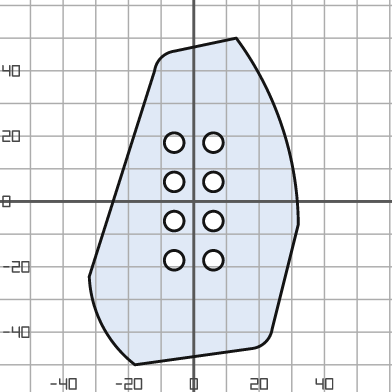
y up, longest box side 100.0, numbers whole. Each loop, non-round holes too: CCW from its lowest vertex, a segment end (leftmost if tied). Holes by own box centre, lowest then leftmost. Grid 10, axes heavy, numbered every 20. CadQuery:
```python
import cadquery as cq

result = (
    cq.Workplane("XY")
    .moveTo(-18.0, -50.0)
    .lineTo(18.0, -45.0)
    .threePointArc((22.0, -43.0), (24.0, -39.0))
    .lineTo(32.0, -7.0)
    .threePointArc((27.0, 23.0), (13.0, 50.0))
    .lineTo(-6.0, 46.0)
    .threePointArc((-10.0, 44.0), (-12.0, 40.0))
    .lineTo(-32.0, -23.0)
    .threePointArc((-28.0, -38.0), (-18.0, -50.0))
    .close()
    .moveTo(-6.0, -18.0)
    .circle(3.0)
    .moveTo(6.0, -18.0)
    .circle(3.0)
    .moveTo(-6.0, -6.0)
    .circle(3.0)
    .moveTo(6.0, -6.0)
    .circle(3.0)
    .moveTo(-6.0, 6.0)
    .circle(3.0)
    .moveTo(6.0, 6.0)
    .circle(3.0)
    .moveTo(-6.0, 18.0)
    .circle(3.0)
    .moveTo(6.0, 18.0)
    .circle(3.0)
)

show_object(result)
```